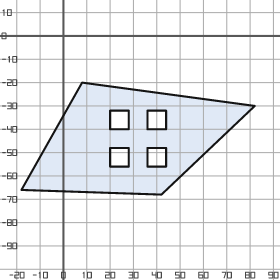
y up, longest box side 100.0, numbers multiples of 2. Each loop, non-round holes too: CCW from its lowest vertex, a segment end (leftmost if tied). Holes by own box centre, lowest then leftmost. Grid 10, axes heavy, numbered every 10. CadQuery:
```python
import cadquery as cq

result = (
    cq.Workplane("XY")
    .moveTo(42.0, -68.0)
    .lineTo(82.0, -30.0)
    .lineTo(8.0, -20.0)
    .lineTo(-18.0, -66.0)
    .close()
    .moveTo(20.0, -56.0)
    .lineTo(28.0, -56.0)
    .lineTo(28.0, -48.0)
    .lineTo(20.0, -48.0)
    .close()
    .moveTo(36.0, -56.0)
    .lineTo(44.0, -56.0)
    .lineTo(44.0, -48.0)
    .lineTo(36.0, -48.0)
    .close()
    .moveTo(20.0, -40.0)
    .lineTo(28.0, -40.0)
    .lineTo(28.0, -32.0)
    .lineTo(20.0, -32.0)
    .close()
    .moveTo(36.0, -40.0)
    .lineTo(44.0, -40.0)
    .lineTo(44.0, -32.0)
    .lineTo(36.0, -32.0)
    .close()
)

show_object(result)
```